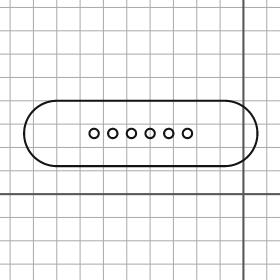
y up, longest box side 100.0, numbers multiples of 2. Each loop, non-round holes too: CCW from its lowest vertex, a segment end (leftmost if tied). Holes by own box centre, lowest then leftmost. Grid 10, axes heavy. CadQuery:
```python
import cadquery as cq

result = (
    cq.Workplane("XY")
    .moveTo(-80.0, 12.0)
    .lineTo(-8.0, 12.0)
    .threePointArc((6.0, 26.0), (-8.0, 40.0))
    .lineTo(-80.0, 40.0)
    .threePointArc((-94.0, 26.0), (-80.0, 12.0))
    .close()
    .moveTo(-64.0, 26.0)
    .circle(2.0)
    .moveTo(-56.0, 26.0)
    .circle(2.0)
    .moveTo(-48.0, 26.0)
    .circle(2.0)
    .moveTo(-40.0, 26.0)
    .circle(2.0)
    .moveTo(-32.0, 26.0)
    .circle(2.0)
    .moveTo(-24.0, 26.0)
    .circle(2.0)
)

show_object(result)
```